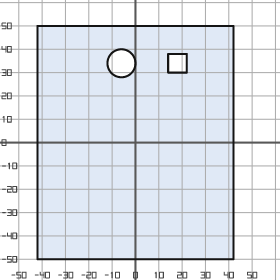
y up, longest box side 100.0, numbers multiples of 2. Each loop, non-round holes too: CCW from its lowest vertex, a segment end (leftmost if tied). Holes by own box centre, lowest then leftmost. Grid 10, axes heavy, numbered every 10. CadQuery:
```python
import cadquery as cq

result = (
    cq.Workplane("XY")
    .moveTo(-42.0, -50.0)
    .lineTo(42.0, -50.0)
    .lineTo(42.0, 50.0)
    .lineTo(-42.0, 50.0)
    .close()
    .moveTo(-6.0, 34.0)
    .circle(6.0)
    .moveTo(14.0, 30.0)
    .lineTo(22.0, 30.0)
    .lineTo(22.0, 38.0)
    .lineTo(14.0, 38.0)
    .close()
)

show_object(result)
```